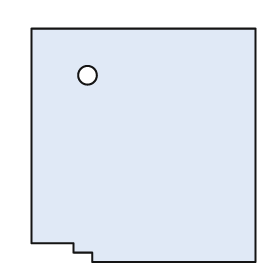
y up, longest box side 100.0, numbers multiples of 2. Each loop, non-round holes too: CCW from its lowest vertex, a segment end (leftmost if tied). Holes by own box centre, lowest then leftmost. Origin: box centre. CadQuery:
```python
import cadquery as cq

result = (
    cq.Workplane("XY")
    .moveTo(-22.0, -50.0)
    .lineTo(48.0, -50.0)
    .lineTo(48.0, 50.0)
    .lineTo(-48.0, 50.0)
    .lineTo(-48.0, -42.0)
    .lineTo(-30.0, -42.0)
    .lineTo(-30.0, -46.0)
    .lineTo(-22.0, -46.0)
    .close()
    .moveTo(-24.0, 30.0)
    .circle(4.0)
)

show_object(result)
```